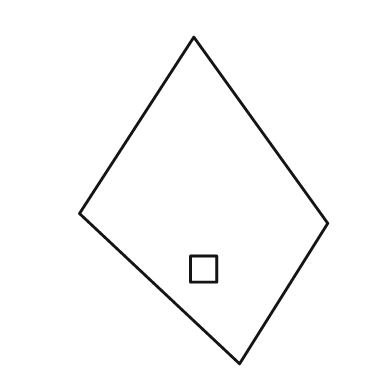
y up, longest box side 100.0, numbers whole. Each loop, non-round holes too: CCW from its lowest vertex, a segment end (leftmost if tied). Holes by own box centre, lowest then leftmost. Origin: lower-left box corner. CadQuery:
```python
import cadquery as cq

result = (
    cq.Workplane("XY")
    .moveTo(49.0, 0.0)
    .lineTo(76.0, 43.0)
    .lineTo(35.0, 100.0)
    .lineTo(0.0, 46.0)
    .close()
    .moveTo(34.0, 25.0)
    .lineTo(42.0, 25.0)
    .lineTo(42.0, 33.0)
    .lineTo(34.0, 33.0)
    .close()
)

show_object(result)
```